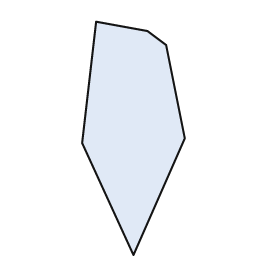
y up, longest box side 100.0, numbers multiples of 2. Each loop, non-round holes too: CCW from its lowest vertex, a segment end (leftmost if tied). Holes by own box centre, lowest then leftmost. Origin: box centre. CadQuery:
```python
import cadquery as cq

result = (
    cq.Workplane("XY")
    .moveTo(0.0, -50.0)
    .lineTo(22.0, 0.0)
    .lineTo(14.0, 40.0)
    .lineTo(6.0, 46.0)
    .lineTo(-16.0, 50.0)
    .lineTo(-22.0, -2.0)
    .close()
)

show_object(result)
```